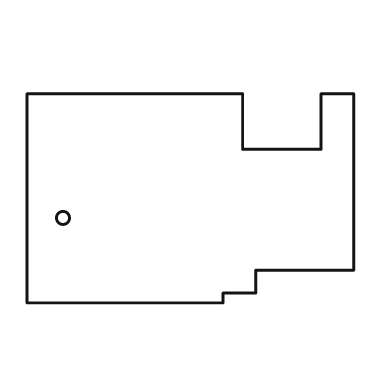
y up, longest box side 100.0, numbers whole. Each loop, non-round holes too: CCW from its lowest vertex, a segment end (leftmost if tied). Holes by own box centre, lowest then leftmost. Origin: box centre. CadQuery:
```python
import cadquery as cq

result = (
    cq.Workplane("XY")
    .moveTo(-50.0, -32.0)
    .lineTo(10.0, -32.0)
    .lineTo(10.0, -29.0)
    .lineTo(20.0, -29.0)
    .lineTo(20.0, -22.0)
    .lineTo(50.0, -22.0)
    .lineTo(50.0, 32.0)
    .lineTo(40.0, 32.0)
    .lineTo(40.0, 15.0)
    .lineTo(16.0, 15.0)
    .lineTo(16.0, 32.0)
    .lineTo(-50.0, 32.0)
    .close()
    .moveTo(-39.0, -6.0)
    .circle(2.0)
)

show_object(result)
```